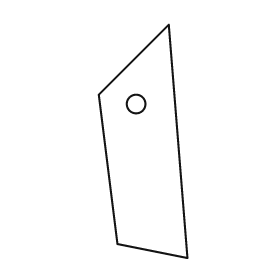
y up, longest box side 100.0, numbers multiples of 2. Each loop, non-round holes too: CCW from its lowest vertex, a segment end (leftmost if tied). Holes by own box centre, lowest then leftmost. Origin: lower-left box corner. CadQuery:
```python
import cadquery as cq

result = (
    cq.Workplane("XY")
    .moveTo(38.0, 0.0)
    .lineTo(30.0, 100.0)
    .lineTo(0.0, 70.0)
    .lineTo(8.0, 6.0)
    .close()
    .moveTo(16.0, 66.0)
    .circle(4.0)
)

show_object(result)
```